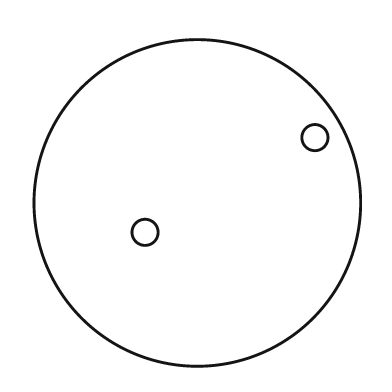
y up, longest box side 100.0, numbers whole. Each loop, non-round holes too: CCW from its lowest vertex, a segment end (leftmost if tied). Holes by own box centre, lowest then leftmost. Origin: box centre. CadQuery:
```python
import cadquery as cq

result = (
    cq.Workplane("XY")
    .moveTo(0.0, 0.0)
    .circle(50.0)
    .moveTo(-16.0, -9.0)
    .circle(4.0)
    .moveTo(36.0, 20.0)
    .circle(4.0)
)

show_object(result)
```